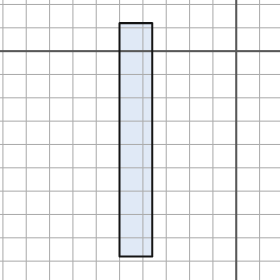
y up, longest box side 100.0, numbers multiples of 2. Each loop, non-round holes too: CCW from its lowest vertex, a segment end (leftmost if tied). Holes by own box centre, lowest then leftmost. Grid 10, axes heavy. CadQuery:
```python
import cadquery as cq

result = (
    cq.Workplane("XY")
    .moveTo(-50.0, -88.0)
    .lineTo(-36.0, -88.0)
    .lineTo(-36.0, 12.0)
    .lineTo(-50.0, 12.0)
    .close()
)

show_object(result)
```